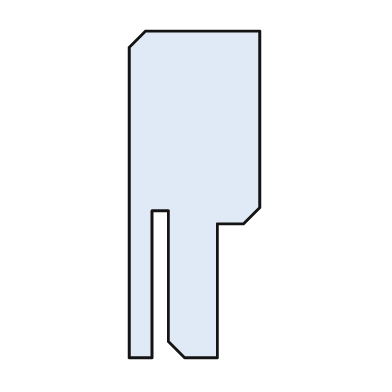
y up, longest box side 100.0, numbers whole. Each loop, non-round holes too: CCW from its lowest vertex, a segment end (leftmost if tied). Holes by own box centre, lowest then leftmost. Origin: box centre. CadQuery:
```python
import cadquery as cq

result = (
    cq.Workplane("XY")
    .moveTo(-20.0, -50.0)
    .lineTo(-13.0, -50.0)
    .lineTo(-13.0, -5.0)
    .lineTo(-8.0, -5.0)
    .lineTo(-8.0, -45.0)
    .lineTo(-3.0, -50.0)
    .lineTo(7.0, -50.0)
    .lineTo(7.0, -9.0)
    .lineTo(15.0, -9.0)
    .lineTo(20.0, -4.0)
    .lineTo(20.0, 50.0)
    .lineTo(-15.0, 50.0)
    .lineTo(-20.0, 45.0)
    .close()
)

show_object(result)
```